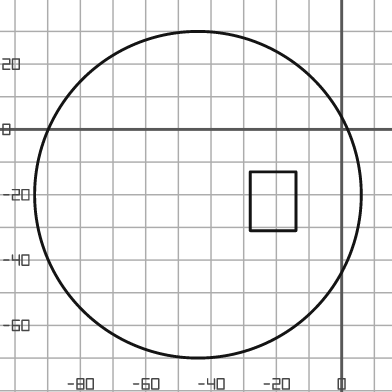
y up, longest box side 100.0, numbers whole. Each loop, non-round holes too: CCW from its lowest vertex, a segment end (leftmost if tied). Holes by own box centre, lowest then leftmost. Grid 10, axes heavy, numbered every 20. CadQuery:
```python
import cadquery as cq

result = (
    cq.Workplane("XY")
    .moveTo(-44.0, -20.0)
    .circle(50.0)
    .moveTo(-28.0, -31.0)
    .lineTo(-14.0, -31.0)
    .lineTo(-14.0, -13.0)
    .lineTo(-28.0, -13.0)
    .close()
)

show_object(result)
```